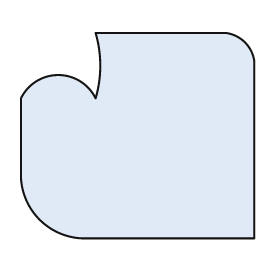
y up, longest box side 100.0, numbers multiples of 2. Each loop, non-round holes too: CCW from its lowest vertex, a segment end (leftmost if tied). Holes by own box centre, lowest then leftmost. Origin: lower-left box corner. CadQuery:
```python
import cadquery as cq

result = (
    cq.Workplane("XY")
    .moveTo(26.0, 0.0)
    .lineTo(100.0, 0.0)
    .lineTo(100.0, 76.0)
    .threePointArc((96.0, 84.0), (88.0, 88.0))
    .lineTo(32.0, 88.0)
    .threePointArc((34.0, 74.0), (32.0, 60.0))
    .threePointArc((16.0, 70.0), (0.0, 60.0))
    .lineTo(0.0, 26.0)
    .threePointArc((8.0, 8.0), (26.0, 0.0))
    .close()
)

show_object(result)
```